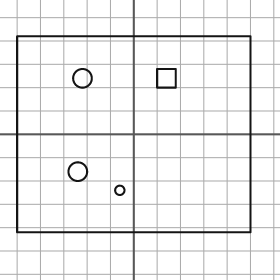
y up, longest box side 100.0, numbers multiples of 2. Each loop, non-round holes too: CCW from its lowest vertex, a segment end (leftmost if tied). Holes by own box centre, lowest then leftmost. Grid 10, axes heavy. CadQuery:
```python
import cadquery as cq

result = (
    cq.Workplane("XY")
    .moveTo(-50.0, -42.0)
    .lineTo(50.0, -42.0)
    .lineTo(50.0, 42.0)
    .lineTo(-50.0, 42.0)
    .close()
    .moveTo(-6.0, -24.0)
    .circle(2.0)
    .moveTo(-24.0, -16.0)
    .circle(4.0)
    .moveTo(-22.0, 24.0)
    .circle(4.0)
    .moveTo(10.0, 20.0)
    .lineTo(18.0, 20.0)
    .lineTo(18.0, 28.0)
    .lineTo(10.0, 28.0)
    .close()
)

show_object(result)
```